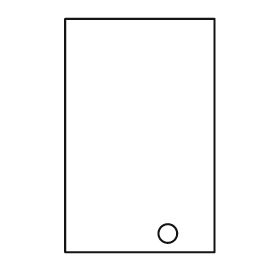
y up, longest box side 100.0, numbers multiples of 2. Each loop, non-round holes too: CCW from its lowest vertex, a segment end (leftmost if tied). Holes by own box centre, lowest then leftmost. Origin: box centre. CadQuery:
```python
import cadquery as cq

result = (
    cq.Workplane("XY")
    .moveTo(-32.0, -50.0)
    .lineTo(32.0, -50.0)
    .lineTo(32.0, 50.0)
    .lineTo(-32.0, 50.0)
    .close()
    .moveTo(12.0, -42.0)
    .circle(4.0)
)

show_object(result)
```